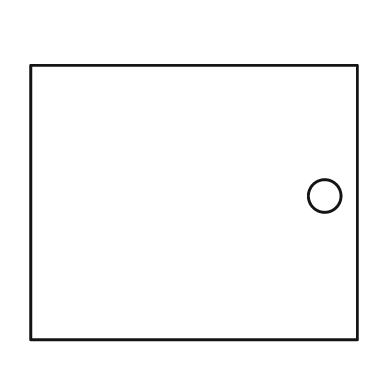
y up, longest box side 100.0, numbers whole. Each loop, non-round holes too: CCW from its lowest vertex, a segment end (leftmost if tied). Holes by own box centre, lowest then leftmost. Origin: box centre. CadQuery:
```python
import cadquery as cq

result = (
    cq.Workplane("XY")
    .moveTo(-50.0, -42.0)
    .lineTo(50.0, -42.0)
    .lineTo(50.0, 42.0)
    .lineTo(-50.0, 42.0)
    .close()
    .moveTo(40.0, 2.0)
    .circle(5.0)
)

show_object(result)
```